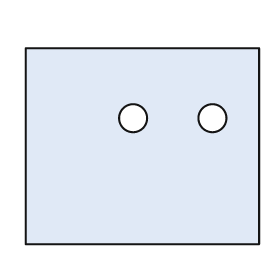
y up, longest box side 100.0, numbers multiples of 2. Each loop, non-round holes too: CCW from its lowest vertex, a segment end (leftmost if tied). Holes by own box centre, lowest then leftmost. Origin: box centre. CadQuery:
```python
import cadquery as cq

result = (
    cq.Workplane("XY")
    .moveTo(-50.0, -42.0)
    .lineTo(50.0, -42.0)
    .lineTo(50.0, 42.0)
    .lineTo(-50.0, 42.0)
    .close()
    .moveTo(-4.0, 12.0)
    .circle(6.0)
    .moveTo(30.0, 12.0)
    .circle(6.0)
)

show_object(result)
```